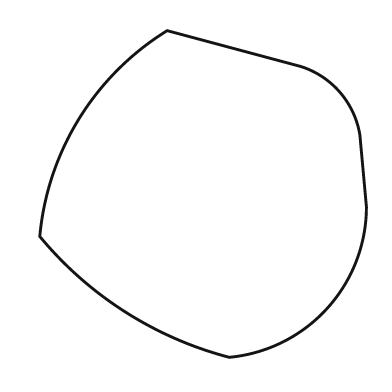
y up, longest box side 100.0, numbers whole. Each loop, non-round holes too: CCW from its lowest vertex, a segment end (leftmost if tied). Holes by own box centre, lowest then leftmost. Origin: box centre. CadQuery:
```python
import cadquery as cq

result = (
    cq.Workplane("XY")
    .moveTo(8.0, -50.0)
    .threePointArc((38.0, -35.0), (50.0, -4.0))
    .lineTo(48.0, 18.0)
    .threePointArc((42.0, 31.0), (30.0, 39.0))
    .lineTo(-11.0, 50.0)
    .threePointArc((-38.0, 23.0), (-50.0, -13.0))
    .threePointArc((-24.0, -36.0), (8.0, -50.0))
    .close()
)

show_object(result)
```